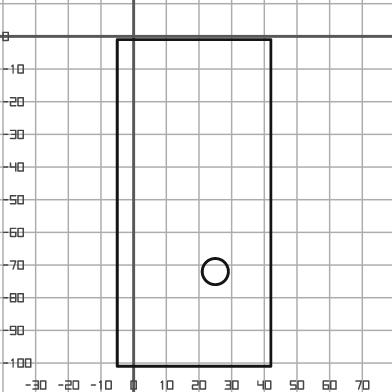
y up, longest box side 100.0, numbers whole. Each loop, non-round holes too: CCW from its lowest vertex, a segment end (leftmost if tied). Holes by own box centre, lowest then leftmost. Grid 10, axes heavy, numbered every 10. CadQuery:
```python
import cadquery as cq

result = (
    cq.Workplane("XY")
    .moveTo(-5.0, -101.0)
    .lineTo(42.0, -101.0)
    .lineTo(42.0, -1.0)
    .lineTo(-5.0, -1.0)
    .close()
    .moveTo(25.0, -72.0)
    .circle(4.0)
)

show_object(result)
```